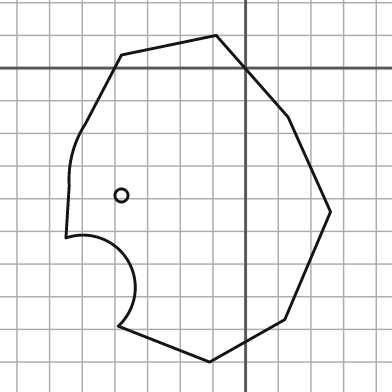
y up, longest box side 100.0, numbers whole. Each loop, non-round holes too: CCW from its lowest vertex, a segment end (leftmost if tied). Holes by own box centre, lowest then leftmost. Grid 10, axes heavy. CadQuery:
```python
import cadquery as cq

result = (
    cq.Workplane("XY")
    .moveTo(-11.0, -90.0)
    .lineTo(12.0, -77.0)
    .lineTo(26.0, -44.0)
    .lineTo(13.0, -15.0)
    .lineTo(-9.0, 10.0)
    .lineTo(-38.0, 4.0)
    .lineTo(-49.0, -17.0)
    .threePointArc((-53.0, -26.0), (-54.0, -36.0))
    .lineTo(-55.0, -52.0)
    .threePointArc((-36.0, -59.0), (-39.0, -79.0))
    .close()
    .moveTo(-38.0, -39.0)
    .circle(2.0)
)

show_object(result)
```